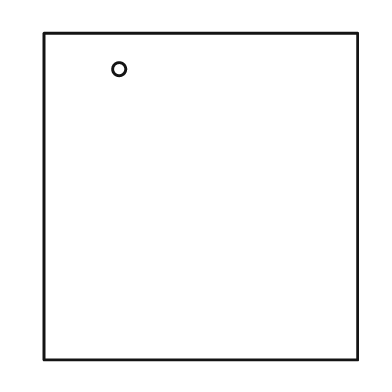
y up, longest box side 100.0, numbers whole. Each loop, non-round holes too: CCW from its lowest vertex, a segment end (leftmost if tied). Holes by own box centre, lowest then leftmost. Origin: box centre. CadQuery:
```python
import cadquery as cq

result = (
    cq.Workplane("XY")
    .moveTo(-48.0, -50.0)
    .lineTo(48.0, -50.0)
    .lineTo(48.0, 50.0)
    .lineTo(-48.0, 50.0)
    .close()
    .moveTo(-25.0, 39.0)
    .circle(2.0)
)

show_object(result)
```